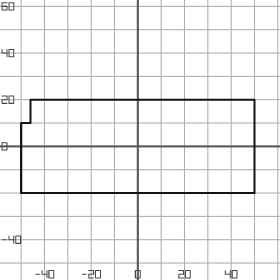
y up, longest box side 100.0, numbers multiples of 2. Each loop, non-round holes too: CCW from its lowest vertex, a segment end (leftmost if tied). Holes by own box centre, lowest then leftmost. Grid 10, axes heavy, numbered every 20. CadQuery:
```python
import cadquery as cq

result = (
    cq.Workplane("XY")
    .moveTo(-50.0, -20.0)
    .lineTo(50.0, -20.0)
    .lineTo(50.0, 20.0)
    .lineTo(-46.0, 20.0)
    .lineTo(-46.0, 10.0)
    .lineTo(-50.0, 10.0)
    .close()
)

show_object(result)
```